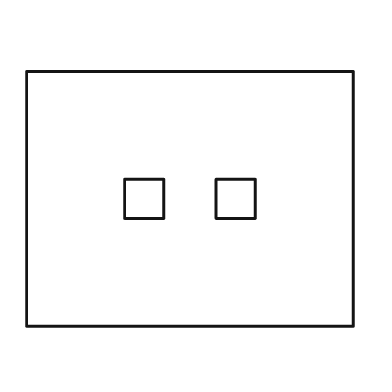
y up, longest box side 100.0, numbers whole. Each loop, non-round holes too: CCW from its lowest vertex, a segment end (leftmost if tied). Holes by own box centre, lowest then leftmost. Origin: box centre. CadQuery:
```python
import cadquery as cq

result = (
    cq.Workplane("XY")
    .moveTo(-50.0, -39.0)
    .lineTo(50.0, -39.0)
    .lineTo(50.0, 39.0)
    .lineTo(-50.0, 39.0)
    .close()
    .moveTo(-20.0, -6.0)
    .lineTo(-8.0, -6.0)
    .lineTo(-8.0, 6.0)
    .lineTo(-20.0, 6.0)
    .close()
    .moveTo(8.0, -6.0)
    .lineTo(20.0, -6.0)
    .lineTo(20.0, 6.0)
    .lineTo(8.0, 6.0)
    .close()
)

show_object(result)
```